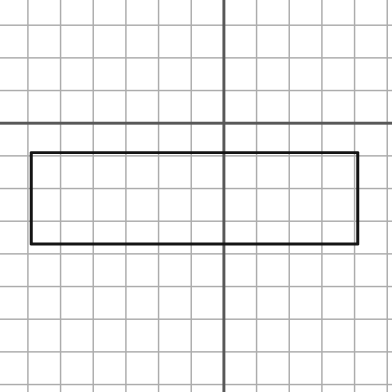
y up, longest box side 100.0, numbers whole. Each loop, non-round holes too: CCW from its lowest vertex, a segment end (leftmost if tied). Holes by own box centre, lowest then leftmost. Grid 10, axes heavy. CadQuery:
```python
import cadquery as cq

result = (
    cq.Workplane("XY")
    .moveTo(-59.0, -37.0)
    .lineTo(41.0, -37.0)
    .lineTo(41.0, -9.0)
    .lineTo(-59.0, -9.0)
    .close()
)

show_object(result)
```